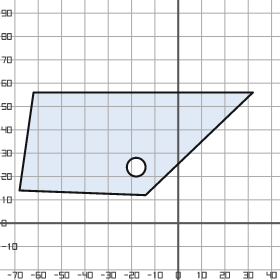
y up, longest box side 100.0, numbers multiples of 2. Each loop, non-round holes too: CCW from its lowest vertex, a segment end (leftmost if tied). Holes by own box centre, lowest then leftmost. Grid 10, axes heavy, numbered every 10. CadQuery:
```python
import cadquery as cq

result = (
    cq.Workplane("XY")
    .moveTo(-14.0, 12.0)
    .lineTo(32.0, 56.0)
    .lineTo(-62.0, 56.0)
    .lineTo(-68.0, 14.0)
    .close()
    .moveTo(-18.0, 24.0)
    .circle(4.0)
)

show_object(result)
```